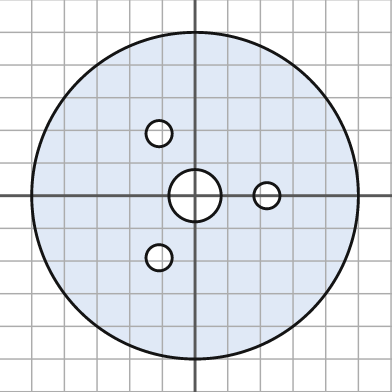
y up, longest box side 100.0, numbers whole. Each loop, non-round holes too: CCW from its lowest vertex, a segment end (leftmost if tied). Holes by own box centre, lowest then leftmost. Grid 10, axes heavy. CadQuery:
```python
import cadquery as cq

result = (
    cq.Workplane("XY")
    .moveTo(0.0, 0.0)
    .circle(50.0)
    .moveTo(-11.0, -19.0)
    .circle(4.0)
    .moveTo(0.0, 0.0)
    .circle(8.0)
    .moveTo(22.0, 0.0)
    .circle(4.0)
    .moveTo(-11.0, 19.0)
    .circle(4.0)
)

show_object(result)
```